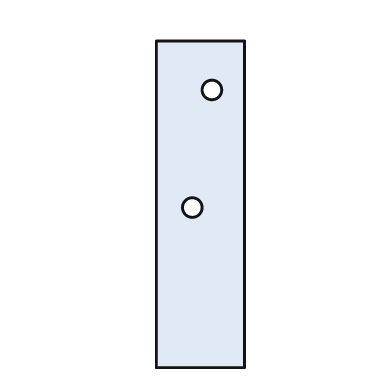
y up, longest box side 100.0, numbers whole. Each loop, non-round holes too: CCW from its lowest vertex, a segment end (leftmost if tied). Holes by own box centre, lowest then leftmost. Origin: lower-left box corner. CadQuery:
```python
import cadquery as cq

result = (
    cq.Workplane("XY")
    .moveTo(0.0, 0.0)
    .lineTo(27.0, 0.0)
    .lineTo(27.0, 100.0)
    .lineTo(0.0, 100.0)
    .close()
    .moveTo(11.0, 49.0)
    .circle(3.0)
    .moveTo(17.0, 85.0)
    .circle(3.0)
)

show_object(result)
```